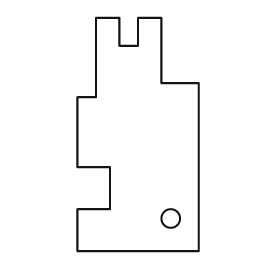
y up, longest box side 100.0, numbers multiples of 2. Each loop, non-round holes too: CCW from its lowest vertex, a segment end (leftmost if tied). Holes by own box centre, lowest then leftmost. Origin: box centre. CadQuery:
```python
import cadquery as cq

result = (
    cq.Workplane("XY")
    .moveTo(-26.0, -50.0)
    .lineTo(26.0, -50.0)
    .lineTo(26.0, 22.0)
    .lineTo(10.0, 22.0)
    .lineTo(10.0, 50.0)
    .lineTo(0.0, 50.0)
    .lineTo(0.0, 38.0)
    .lineTo(-8.0, 38.0)
    .lineTo(-8.0, 50.0)
    .lineTo(-18.0, 50.0)
    .lineTo(-18.0, 16.0)
    .lineTo(-26.0, 16.0)
    .lineTo(-26.0, -14.0)
    .lineTo(-12.0, -14.0)
    .lineTo(-12.0, -32.0)
    .lineTo(-26.0, -32.0)
    .close()
    .moveTo(14.0, -36.0)
    .circle(4.0)
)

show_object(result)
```